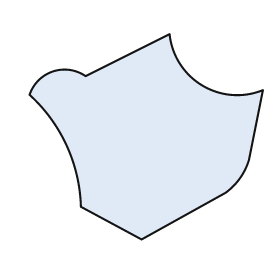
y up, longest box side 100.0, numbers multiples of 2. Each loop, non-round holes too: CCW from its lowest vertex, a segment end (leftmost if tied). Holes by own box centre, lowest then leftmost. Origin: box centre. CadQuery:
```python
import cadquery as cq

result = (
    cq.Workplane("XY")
    .moveTo(-2.0, -44.0)
    .lineTo(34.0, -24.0)
    .threePointArc((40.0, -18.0), (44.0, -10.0))
    .lineTo(50.0, 20.0)
    .threePointArc((24.0, 22.0), (10.0, 44.0))
    .lineTo(-26.0, 26.0)
    .threePointArc((-40.0, 28.0), (-50.0, 18.0))
    .threePointArc((-34.0, -4.0), (-28.0, -30.0))
    .close()
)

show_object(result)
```